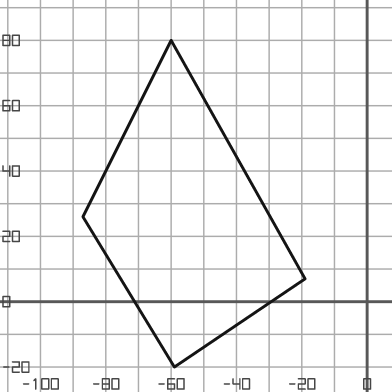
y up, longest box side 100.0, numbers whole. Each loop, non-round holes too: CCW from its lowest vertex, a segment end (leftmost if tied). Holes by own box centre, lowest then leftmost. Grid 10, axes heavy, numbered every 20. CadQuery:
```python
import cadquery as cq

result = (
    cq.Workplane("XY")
    .moveTo(-59.0, -20.0)
    .lineTo(-19.0, 7.0)
    .lineTo(-60.0, 80.0)
    .lineTo(-87.0, 26.0)
    .close()
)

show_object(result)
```